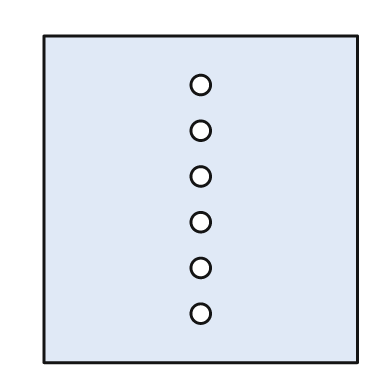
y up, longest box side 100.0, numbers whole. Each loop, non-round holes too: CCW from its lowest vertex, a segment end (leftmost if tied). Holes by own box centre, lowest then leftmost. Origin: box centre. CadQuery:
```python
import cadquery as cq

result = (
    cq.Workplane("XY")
    .moveTo(-48.0, -50.0)
    .lineTo(48.0, -50.0)
    .lineTo(48.0, 50.0)
    .lineTo(-48.0, 50.0)
    .close()
    .moveTo(0.0, -35.0)
    .circle(3.0)
    .moveTo(0.0, -21.0)
    .circle(3.0)
    .moveTo(0.0, -7.0)
    .circle(3.0)
    .moveTo(0.0, 7.0)
    .circle(3.0)
    .moveTo(0.0, 21.0)
    .circle(3.0)
    .moveTo(0.0, 35.0)
    .circle(3.0)
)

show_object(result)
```